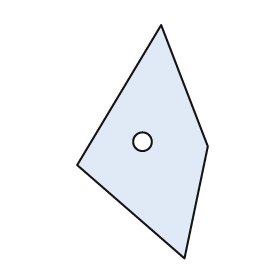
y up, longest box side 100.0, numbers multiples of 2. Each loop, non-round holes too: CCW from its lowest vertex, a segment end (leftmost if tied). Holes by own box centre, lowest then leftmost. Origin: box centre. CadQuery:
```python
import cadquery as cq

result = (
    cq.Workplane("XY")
    .moveTo(18.0, -50.0)
    .lineTo(28.0, -2.0)
    .lineTo(8.0, 50.0)
    .lineTo(-28.0, -10.0)
    .close()
    .moveTo(0.0, 0.0)
    .circle(4.0)
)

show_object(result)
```